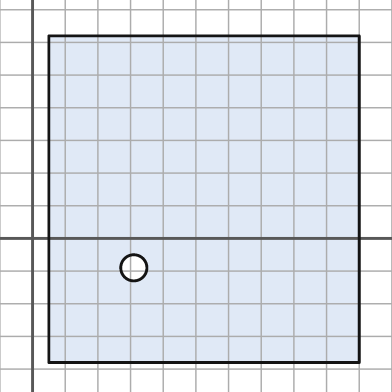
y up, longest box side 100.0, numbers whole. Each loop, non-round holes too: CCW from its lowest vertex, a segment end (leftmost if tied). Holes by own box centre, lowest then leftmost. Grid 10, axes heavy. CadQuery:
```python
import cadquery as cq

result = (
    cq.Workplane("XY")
    .moveTo(5.0, -38.0)
    .lineTo(100.0, -38.0)
    .lineTo(100.0, 62.0)
    .lineTo(5.0, 62.0)
    .close()
    .moveTo(31.0, -9.0)
    .circle(4.0)
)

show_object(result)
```